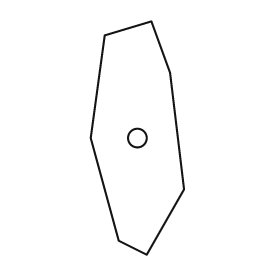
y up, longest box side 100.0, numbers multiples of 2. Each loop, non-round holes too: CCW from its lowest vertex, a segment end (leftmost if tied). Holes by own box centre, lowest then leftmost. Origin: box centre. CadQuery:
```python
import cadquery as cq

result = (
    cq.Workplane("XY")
    .moveTo(4.0, -50.0)
    .lineTo(20.0, -22.0)
    .lineTo(14.0, 28.0)
    .lineTo(6.0, 50.0)
    .lineTo(-14.0, 44.0)
    .lineTo(-20.0, 0.0)
    .lineTo(-8.0, -44.0)
    .close()
    .moveTo(0.0, 0.0)
    .circle(4.0)
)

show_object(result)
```